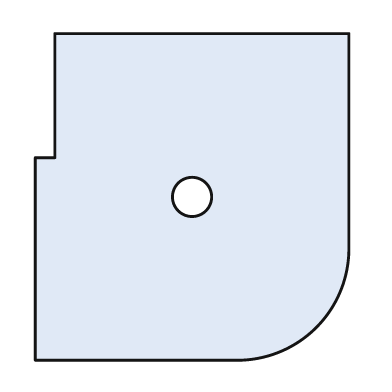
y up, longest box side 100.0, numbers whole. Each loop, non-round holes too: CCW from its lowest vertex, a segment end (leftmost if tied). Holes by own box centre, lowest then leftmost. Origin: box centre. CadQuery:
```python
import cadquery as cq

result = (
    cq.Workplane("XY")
    .moveTo(-48.0, -50.0)
    .lineTo(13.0, -50.0)
    .threePointArc((38.0, -40.0), (48.0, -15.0))
    .lineTo(48.0, 50.0)
    .lineTo(-42.0, 50.0)
    .lineTo(-42.0, 12.0)
    .lineTo(-48.0, 12.0)
    .close()
    .moveTo(0.0, 0.0)
    .circle(6.0)
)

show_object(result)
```